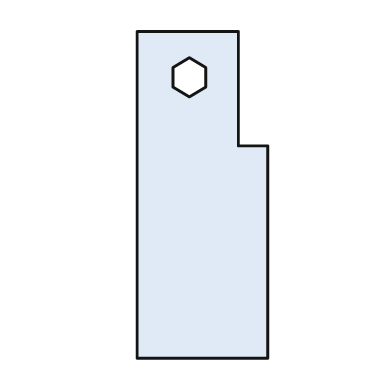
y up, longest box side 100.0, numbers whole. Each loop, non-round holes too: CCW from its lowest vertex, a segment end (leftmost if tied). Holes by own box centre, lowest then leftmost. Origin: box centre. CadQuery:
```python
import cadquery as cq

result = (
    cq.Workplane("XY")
    .moveTo(-20.0, -50.0)
    .lineTo(20.0, -50.0)
    .lineTo(20.0, 15.0)
    .lineTo(11.0, 15.0)
    .lineTo(11.0, 50.0)
    .lineTo(-20.0, 50.0)
    .close()
    .moveTo(-4.0, 30.0)
    .lineTo(1.0, 33.0)
    .lineTo(1.0, 39.0)
    .lineTo(-4.0, 42.0)
    .lineTo(-9.0, 39.0)
    .lineTo(-9.0, 33.0)
    .close()
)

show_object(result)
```